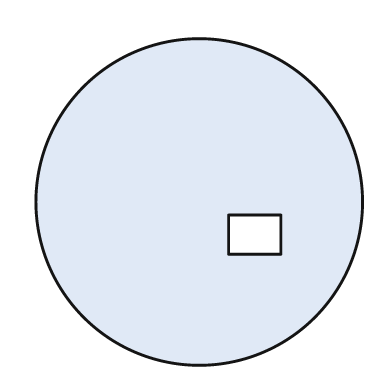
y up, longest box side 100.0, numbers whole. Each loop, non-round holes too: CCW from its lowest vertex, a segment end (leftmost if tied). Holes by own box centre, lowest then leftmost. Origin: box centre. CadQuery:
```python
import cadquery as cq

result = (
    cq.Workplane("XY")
    .moveTo(0.0, 0.0)
    .circle(50.0)
    .moveTo(9.0, -16.0)
    .lineTo(25.0, -16.0)
    .lineTo(25.0, -4.0)
    .lineTo(9.0, -4.0)
    .close()
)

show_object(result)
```